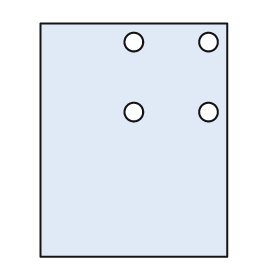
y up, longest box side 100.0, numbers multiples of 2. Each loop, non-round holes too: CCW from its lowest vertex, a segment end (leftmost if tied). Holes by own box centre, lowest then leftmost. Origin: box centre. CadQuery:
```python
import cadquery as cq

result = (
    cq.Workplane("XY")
    .moveTo(-40.0, -50.0)
    .lineTo(40.0, -50.0)
    .lineTo(40.0, 50.0)
    .lineTo(-40.0, 50.0)
    .close()
    .moveTo(0.0, 12.0)
    .circle(4.0)
    .moveTo(32.0, 12.0)
    .circle(4.0)
    .moveTo(0.0, 42.0)
    .circle(4.0)
    .moveTo(32.0, 42.0)
    .circle(4.0)
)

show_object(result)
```